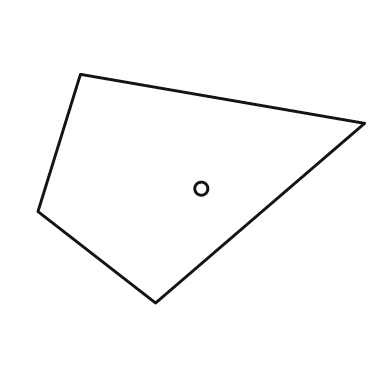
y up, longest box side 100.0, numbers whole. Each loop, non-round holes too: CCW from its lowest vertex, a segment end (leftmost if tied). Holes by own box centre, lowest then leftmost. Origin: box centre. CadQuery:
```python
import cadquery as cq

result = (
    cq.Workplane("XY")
    .moveTo(-14.0, -35.0)
    .lineTo(50.0, 20.0)
    .lineTo(-37.0, 35.0)
    .lineTo(-50.0, -7.0)
    .close()
    .moveTo(0.0, 0.0)
    .circle(2.0)
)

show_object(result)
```